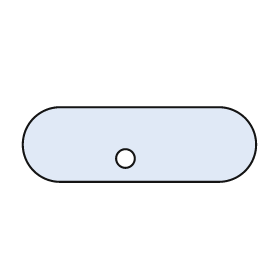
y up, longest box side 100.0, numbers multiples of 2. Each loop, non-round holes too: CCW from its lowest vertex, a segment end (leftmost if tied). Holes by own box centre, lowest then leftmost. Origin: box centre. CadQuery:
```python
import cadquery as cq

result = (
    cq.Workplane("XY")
    .moveTo(-34.0, -16.0)
    .lineTo(34.0, -16.0)
    .threePointArc((50.0, 0.0), (34.0, 16.0))
    .lineTo(-34.0, 16.0)
    .threePointArc((-50.0, 0.0), (-34.0, -16.0))
    .close()
    .moveTo(-6.0, -6.0)
    .circle(4.0)
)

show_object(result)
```